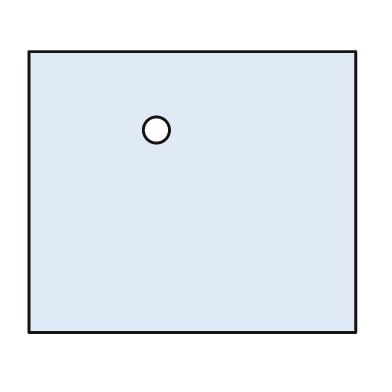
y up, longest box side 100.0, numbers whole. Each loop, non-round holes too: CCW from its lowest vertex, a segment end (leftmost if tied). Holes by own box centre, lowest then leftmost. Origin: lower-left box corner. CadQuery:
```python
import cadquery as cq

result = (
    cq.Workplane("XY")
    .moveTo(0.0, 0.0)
    .lineTo(100.0, 0.0)
    .lineTo(100.0, 86.0)
    .lineTo(0.0, 86.0)
    .close()
    .moveTo(39.0, 62.0)
    .circle(4.0)
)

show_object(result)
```